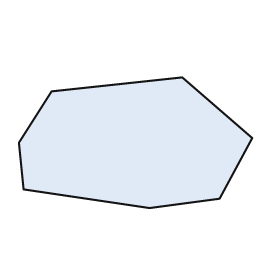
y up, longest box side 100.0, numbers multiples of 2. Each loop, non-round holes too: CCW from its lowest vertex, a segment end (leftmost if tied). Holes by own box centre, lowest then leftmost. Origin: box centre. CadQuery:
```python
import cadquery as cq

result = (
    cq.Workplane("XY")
    .moveTo(6.0, -28.0)
    .lineTo(36.0, -24.0)
    .lineTo(50.0, 2.0)
    .lineTo(20.0, 28.0)
    .lineTo(-36.0, 22.0)
    .lineTo(-50.0, 0.0)
    .lineTo(-48.0, -20.0)
    .close()
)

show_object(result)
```